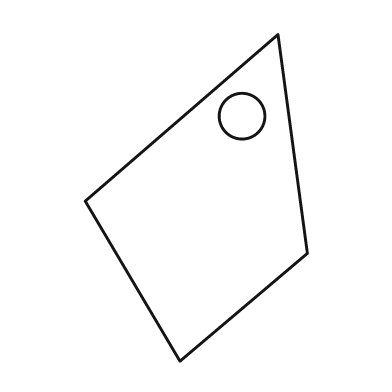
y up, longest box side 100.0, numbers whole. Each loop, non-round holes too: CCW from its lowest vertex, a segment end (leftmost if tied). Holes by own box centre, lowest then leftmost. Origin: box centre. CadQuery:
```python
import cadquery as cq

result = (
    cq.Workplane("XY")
    .moveTo(-5.0, -50.0)
    .lineTo(34.0, -17.0)
    .lineTo(25.0, 50.0)
    .lineTo(-34.0, -1.0)
    .close()
    .moveTo(14.0, 25.0)
    .circle(7.0)
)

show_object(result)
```